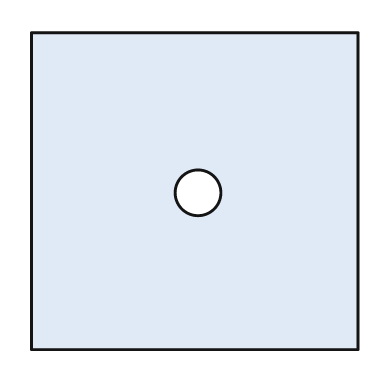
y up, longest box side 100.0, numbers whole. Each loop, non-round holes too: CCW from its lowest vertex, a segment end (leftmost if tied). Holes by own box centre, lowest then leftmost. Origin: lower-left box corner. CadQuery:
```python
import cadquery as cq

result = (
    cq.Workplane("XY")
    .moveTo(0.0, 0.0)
    .lineTo(100.0, 0.0)
    .lineTo(100.0, 97.0)
    .lineTo(0.0, 97.0)
    .close()
    .moveTo(51.0, 48.0)
    .circle(7.0)
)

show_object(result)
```